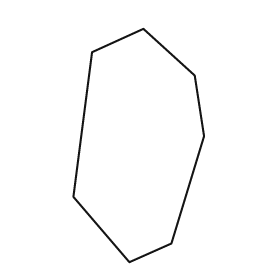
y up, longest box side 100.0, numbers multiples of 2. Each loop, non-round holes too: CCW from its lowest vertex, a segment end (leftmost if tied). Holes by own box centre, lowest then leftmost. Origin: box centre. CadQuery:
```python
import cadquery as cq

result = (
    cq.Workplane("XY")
    .moveTo(-4.0, -50.0)
    .lineTo(14.0, -42.0)
    .lineTo(28.0, 4.0)
    .lineTo(24.0, 30.0)
    .lineTo(2.0, 50.0)
    .lineTo(-20.0, 40.0)
    .lineTo(-28.0, -22.0)
    .close()
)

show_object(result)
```